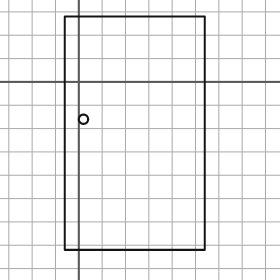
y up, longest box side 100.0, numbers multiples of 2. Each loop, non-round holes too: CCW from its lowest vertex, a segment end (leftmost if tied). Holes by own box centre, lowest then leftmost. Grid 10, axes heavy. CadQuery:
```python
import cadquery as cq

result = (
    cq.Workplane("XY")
    .moveTo(-6.0, -72.0)
    .lineTo(54.0, -72.0)
    .lineTo(54.0, 28.0)
    .lineTo(-6.0, 28.0)
    .close()
    .moveTo(2.0, -16.0)
    .circle(2.0)
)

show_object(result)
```